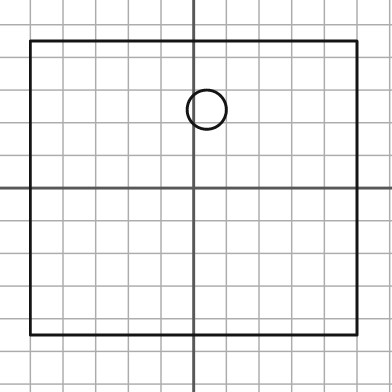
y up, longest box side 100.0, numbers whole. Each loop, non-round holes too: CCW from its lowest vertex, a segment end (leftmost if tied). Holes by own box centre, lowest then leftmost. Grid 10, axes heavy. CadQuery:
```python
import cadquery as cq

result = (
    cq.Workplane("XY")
    .moveTo(-50.0, -45.0)
    .lineTo(50.0, -45.0)
    .lineTo(50.0, 45.0)
    .lineTo(-50.0, 45.0)
    .close()
    .moveTo(4.0, 24.0)
    .circle(6.0)
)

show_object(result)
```